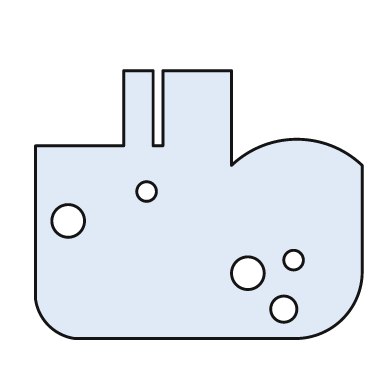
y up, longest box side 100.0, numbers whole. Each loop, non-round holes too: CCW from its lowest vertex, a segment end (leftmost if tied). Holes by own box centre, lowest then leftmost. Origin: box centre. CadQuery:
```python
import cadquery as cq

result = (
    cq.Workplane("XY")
    .moveTo(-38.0, -41.0)
    .lineTo(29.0, -41.0)
    .threePointArc((44.0, -35.0), (50.0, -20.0))
    .lineTo(50.0, 12.0)
    .threePointArc((30.0, 20.0), (10.0, 12.0))
    .lineTo(10.0, 41.0)
    .lineTo(-11.0, 41.0)
    .lineTo(-11.0, 18.0)
    .lineTo(-14.0, 18.0)
    .lineTo(-14.0, 41.0)
    .lineTo(-23.0, 41.0)
    .lineTo(-23.0, 18.0)
    .lineTo(-50.0, 18.0)
    .lineTo(-50.0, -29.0)
    .threePointArc((-46.0, -37.0), (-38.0, -41.0))
    .close()
    .moveTo(26.0, -32.0)
    .circle(4.0)
    .moveTo(15.0, -21.0)
    .circle(5.0)
    .moveTo(29.0, -17.0)
    .circle(3.0)
    .moveTo(-40.0, -5.0)
    .circle(5.0)
    .moveTo(-16.0, 4.0)
    .circle(3.0)
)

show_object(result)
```